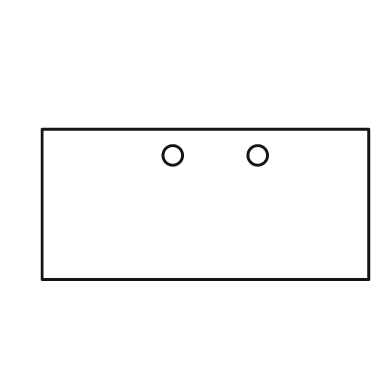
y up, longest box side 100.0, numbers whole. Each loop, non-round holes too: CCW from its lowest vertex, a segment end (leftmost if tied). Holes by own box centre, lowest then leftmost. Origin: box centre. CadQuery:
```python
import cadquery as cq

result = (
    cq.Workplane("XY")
    .moveTo(-50.0, -23.0)
    .lineTo(50.0, -23.0)
    .lineTo(50.0, 23.0)
    .lineTo(-50.0, 23.0)
    .close()
    .moveTo(-10.0, 15.0)
    .circle(3.0)
    .moveTo(16.0, 15.0)
    .circle(3.0)
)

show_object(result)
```